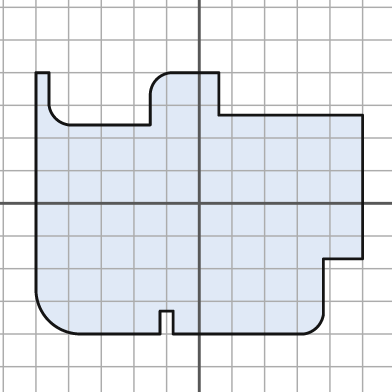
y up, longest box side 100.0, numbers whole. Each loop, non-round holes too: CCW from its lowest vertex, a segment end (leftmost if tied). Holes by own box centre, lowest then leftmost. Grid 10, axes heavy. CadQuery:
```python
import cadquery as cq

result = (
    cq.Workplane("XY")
    .moveTo(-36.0, -40.0)
    .lineTo(-12.0, -40.0)
    .lineTo(-12.0, -33.0)
    .lineTo(-8.0, -33.0)
    .lineTo(-8.0, -40.0)
    .lineTo(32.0, -40.0)
    .threePointArc((36.0, -38.0), (38.0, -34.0))
    .lineTo(38.0, -17.0)
    .lineTo(50.0, -17.0)
    .lineTo(50.0, 27.0)
    .lineTo(6.0, 27.0)
    .lineTo(6.0, 40.0)
    .lineTo(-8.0, 40.0)
    .threePointArc((-13.0, 38.0), (-15.0, 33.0))
    .lineTo(-15.0, 24.0)
    .lineTo(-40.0, 24.0)
    .threePointArc((-44.0, 26.0), (-46.0, 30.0))
    .lineTo(-46.0, 40.0)
    .lineTo(-50.0, 40.0)
    .lineTo(-50.0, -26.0)
    .threePointArc((-46.0, -36.0), (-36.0, -40.0))
    .close()
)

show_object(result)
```